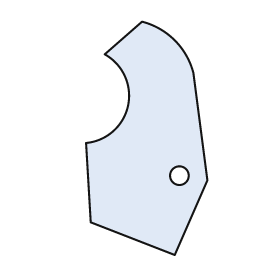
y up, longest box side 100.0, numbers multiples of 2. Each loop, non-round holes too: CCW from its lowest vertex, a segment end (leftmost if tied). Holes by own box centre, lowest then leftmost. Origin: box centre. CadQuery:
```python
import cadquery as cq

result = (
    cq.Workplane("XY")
    .moveTo(12.0, -50.0)
    .lineTo(26.0, -18.0)
    .lineTo(20.0, 28.0)
    .threePointArc((12.0, 42.0), (-2.0, 50.0))
    .lineTo(-18.0, 36.0)
    .threePointArc((-8.0, 14.0), (-26.0, -2.0))
    .lineTo(-24.0, -36.0)
    .close()
    .moveTo(14.0, -16.0)
    .circle(4.0)
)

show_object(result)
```